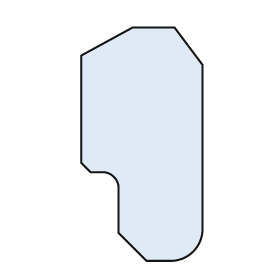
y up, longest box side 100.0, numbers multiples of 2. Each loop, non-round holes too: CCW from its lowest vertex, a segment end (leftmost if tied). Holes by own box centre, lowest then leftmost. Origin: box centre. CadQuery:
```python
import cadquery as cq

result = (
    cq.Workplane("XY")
    .moveTo(2.0, -50.0)
    .lineTo(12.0, -50.0)
    .threePointArc((22.0, -46.0), (26.0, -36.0))
    .lineTo(26.0, 34.0)
    .lineTo(14.0, 50.0)
    .lineTo(-4.0, 50.0)
    .lineTo(-26.0, 38.0)
    .lineTo(-26.0, -8.0)
    .lineTo(-22.0, -12.0)
    .lineTo(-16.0, -12.0)
    .threePointArc((-12.0, -14.0), (-10.0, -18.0))
    .lineTo(-10.0, -38.0)
    .close()
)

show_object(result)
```